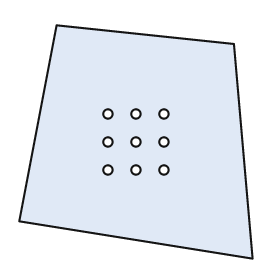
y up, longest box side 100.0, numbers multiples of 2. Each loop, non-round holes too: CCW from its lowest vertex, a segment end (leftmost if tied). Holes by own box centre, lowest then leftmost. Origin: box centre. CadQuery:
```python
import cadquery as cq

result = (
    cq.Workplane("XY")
    .moveTo(50.0, -50.0)
    .lineTo(42.0, 42.0)
    .lineTo(-34.0, 50.0)
    .lineTo(-50.0, -34.0)
    .close()
    .moveTo(-12.0, -12.0)
    .circle(2.0)
    .moveTo(0.0, -12.0)
    .circle(2.0)
    .moveTo(12.0, -12.0)
    .circle(2.0)
    .moveTo(-12.0, 0.0)
    .circle(2.0)
    .moveTo(0.0, 0.0)
    .circle(2.0)
    .moveTo(12.0, 0.0)
    .circle(2.0)
    .moveTo(-12.0, 12.0)
    .circle(2.0)
    .moveTo(0.0, 12.0)
    .circle(2.0)
    .moveTo(12.0, 12.0)
    .circle(2.0)
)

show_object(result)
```